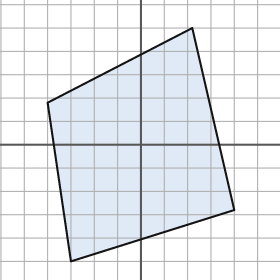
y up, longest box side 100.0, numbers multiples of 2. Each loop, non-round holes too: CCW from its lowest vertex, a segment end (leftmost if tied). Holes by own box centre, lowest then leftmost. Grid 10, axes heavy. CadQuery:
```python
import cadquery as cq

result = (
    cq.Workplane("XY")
    .moveTo(-30.0, -50.0)
    .lineTo(40.0, -28.0)
    .lineTo(22.0, 50.0)
    .lineTo(-40.0, 18.0)
    .close()
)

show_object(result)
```